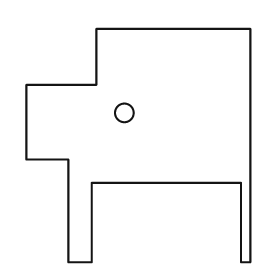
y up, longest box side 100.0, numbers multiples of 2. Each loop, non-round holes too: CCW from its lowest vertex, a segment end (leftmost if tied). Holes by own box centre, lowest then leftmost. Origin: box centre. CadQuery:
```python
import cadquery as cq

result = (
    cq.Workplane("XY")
    .moveTo(-30.0, -50.0)
    .lineTo(-20.0, -50.0)
    .lineTo(-20.0, -16.0)
    .lineTo(44.0, -16.0)
    .lineTo(44.0, -50.0)
    .lineTo(48.0, -50.0)
    .lineTo(48.0, 50.0)
    .lineTo(-18.0, 50.0)
    .lineTo(-18.0, 26.0)
    .lineTo(-48.0, 26.0)
    .lineTo(-48.0, -6.0)
    .lineTo(-30.0, -6.0)
    .close()
    .moveTo(-6.0, 14.0)
    .circle(4.0)
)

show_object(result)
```